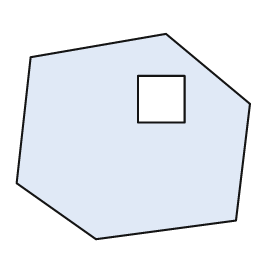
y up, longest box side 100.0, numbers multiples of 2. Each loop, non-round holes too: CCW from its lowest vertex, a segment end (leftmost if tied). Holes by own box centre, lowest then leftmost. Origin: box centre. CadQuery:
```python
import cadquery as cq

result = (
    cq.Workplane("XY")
    .moveTo(-16.0, -44.0)
    .lineTo(44.0, -36.0)
    .lineTo(50.0, 14.0)
    .lineTo(14.0, 44.0)
    .lineTo(-44.0, 34.0)
    .lineTo(-50.0, -20.0)
    .close()
    .moveTo(2.0, 6.0)
    .lineTo(22.0, 6.0)
    .lineTo(22.0, 26.0)
    .lineTo(2.0, 26.0)
    .close()
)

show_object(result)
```